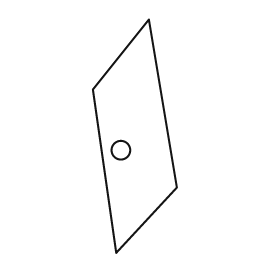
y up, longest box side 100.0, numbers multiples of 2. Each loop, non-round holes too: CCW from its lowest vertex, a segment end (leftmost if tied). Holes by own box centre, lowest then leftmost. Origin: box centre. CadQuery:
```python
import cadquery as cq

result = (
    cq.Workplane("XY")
    .moveTo(-8.0, -50.0)
    .lineTo(18.0, -22.0)
    .lineTo(6.0, 50.0)
    .lineTo(-18.0, 20.0)
    .close()
    .moveTo(-6.0, -6.0)
    .circle(4.0)
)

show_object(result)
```